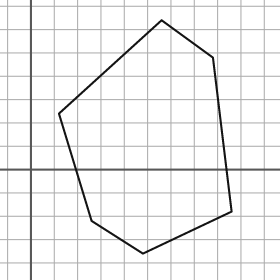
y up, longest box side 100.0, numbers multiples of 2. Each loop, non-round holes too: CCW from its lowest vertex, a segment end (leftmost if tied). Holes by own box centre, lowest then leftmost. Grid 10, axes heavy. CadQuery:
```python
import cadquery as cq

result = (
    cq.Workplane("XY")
    .moveTo(48.0, -36.0)
    .lineTo(86.0, -18.0)
    .lineTo(78.0, 48.0)
    .lineTo(56.0, 64.0)
    .lineTo(12.0, 24.0)
    .lineTo(26.0, -22.0)
    .close()
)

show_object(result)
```